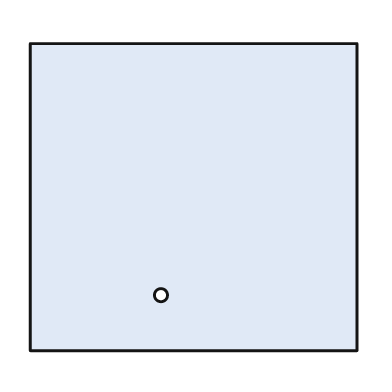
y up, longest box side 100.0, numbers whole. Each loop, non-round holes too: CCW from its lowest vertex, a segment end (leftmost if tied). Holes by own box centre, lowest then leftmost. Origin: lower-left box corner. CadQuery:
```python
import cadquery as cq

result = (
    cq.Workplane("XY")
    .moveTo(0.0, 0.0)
    .lineTo(100.0, 0.0)
    .lineTo(100.0, 94.0)
    .lineTo(0.0, 94.0)
    .close()
    .moveTo(40.0, 17.0)
    .circle(2.0)
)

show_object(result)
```